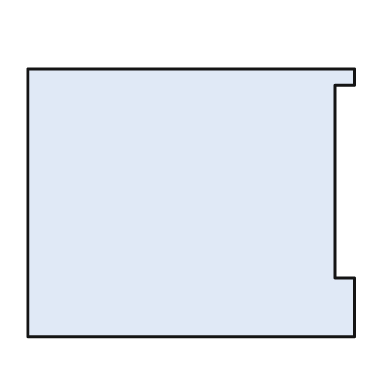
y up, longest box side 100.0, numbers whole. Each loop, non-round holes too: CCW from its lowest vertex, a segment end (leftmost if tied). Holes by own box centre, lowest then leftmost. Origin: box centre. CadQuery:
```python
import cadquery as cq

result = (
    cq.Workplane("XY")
    .moveTo(-50.0, -41.0)
    .lineTo(50.0, -41.0)
    .lineTo(50.0, -23.0)
    .lineTo(44.0, -23.0)
    .lineTo(44.0, 36.0)
    .lineTo(50.0, 36.0)
    .lineTo(50.0, 41.0)
    .lineTo(-50.0, 41.0)
    .close()
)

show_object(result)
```